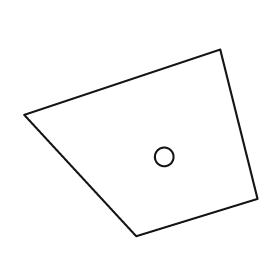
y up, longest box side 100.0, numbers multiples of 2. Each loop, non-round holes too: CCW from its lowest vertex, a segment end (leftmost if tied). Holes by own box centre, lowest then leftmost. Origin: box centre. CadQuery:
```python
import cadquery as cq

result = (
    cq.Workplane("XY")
    .moveTo(-2.0, -40.0)
    .lineTo(50.0, -24.0)
    .lineTo(34.0, 40.0)
    .lineTo(-50.0, 12.0)
    .close()
    .moveTo(10.0, -6.0)
    .circle(4.0)
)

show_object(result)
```